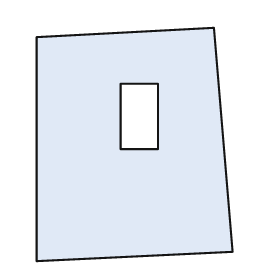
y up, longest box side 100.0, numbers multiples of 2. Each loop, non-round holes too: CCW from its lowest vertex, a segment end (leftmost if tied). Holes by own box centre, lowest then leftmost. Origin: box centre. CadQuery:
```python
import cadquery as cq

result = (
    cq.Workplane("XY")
    .moveTo(-42.0, -50.0)
    .lineTo(42.0, -46.0)
    .lineTo(34.0, 50.0)
    .lineTo(-42.0, 46.0)
    .close()
    .moveTo(-6.0, -2.0)
    .lineTo(10.0, -2.0)
    .lineTo(10.0, 26.0)
    .lineTo(-6.0, 26.0)
    .close()
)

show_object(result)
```